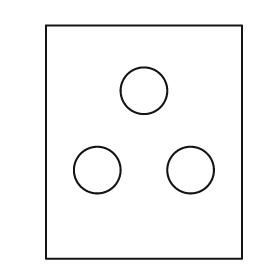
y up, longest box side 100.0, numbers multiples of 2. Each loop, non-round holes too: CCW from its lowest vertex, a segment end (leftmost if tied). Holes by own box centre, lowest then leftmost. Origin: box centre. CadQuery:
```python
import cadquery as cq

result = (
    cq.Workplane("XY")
    .moveTo(-42.0, -50.0)
    .lineTo(42.0, -50.0)
    .lineTo(42.0, 50.0)
    .lineTo(-42.0, 50.0)
    .close()
    .moveTo(-20.0, -12.0)
    .circle(10.0)
    .moveTo(20.0, -12.0)
    .circle(10.0)
    .moveTo(0.0, 22.0)
    .circle(10.0)
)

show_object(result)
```